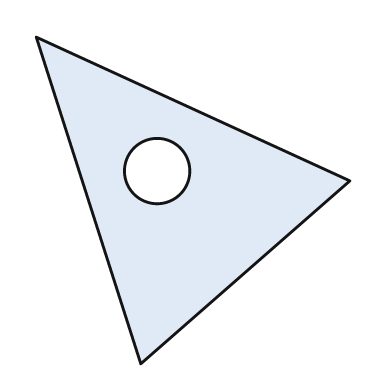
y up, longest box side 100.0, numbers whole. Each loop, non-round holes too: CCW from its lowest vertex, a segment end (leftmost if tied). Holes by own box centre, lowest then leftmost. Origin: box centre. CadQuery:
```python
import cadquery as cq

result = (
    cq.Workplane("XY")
    .moveTo(-16.0, -50.0)
    .lineTo(48.0, 6.0)
    .lineTo(-48.0, 50.0)
    .close()
    .moveTo(-11.0, 9.0)
    .circle(10.0)
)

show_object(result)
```